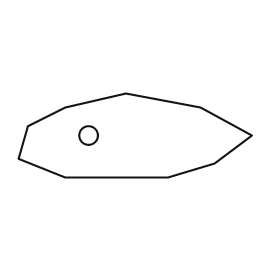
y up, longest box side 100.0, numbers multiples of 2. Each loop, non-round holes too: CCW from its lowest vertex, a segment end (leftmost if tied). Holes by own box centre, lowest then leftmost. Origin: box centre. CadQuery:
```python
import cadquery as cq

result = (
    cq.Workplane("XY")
    .moveTo(-30.0, -18.0)
    .lineTo(14.0, -18.0)
    .lineTo(34.0, -12.0)
    .lineTo(50.0, 0.0)
    .lineTo(28.0, 12.0)
    .lineTo(-4.0, 18.0)
    .lineTo(-30.0, 12.0)
    .lineTo(-46.0, 4.0)
    .lineTo(-50.0, -10.0)
    .close()
    .moveTo(-20.0, 0.0)
    .circle(4.0)
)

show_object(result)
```